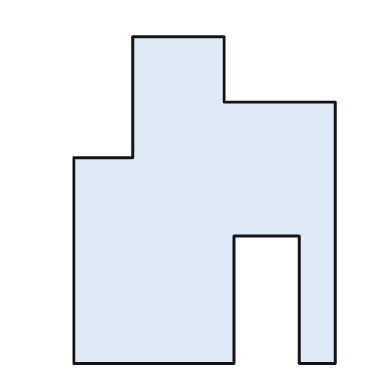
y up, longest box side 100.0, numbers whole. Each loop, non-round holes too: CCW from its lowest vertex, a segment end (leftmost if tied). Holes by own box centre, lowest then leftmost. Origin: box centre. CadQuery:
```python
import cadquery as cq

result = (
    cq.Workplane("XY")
    .moveTo(-40.0, -50.0)
    .lineTo(9.0, -50.0)
    .lineTo(9.0, -11.0)
    .lineTo(29.0, -11.0)
    .lineTo(29.0, -50.0)
    .lineTo(40.0, -50.0)
    .lineTo(40.0, 30.0)
    .lineTo(6.0, 30.0)
    .lineTo(6.0, 50.0)
    .lineTo(-22.0, 50.0)
    .lineTo(-22.0, 13.0)
    .lineTo(-40.0, 13.0)
    .close()
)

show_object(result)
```